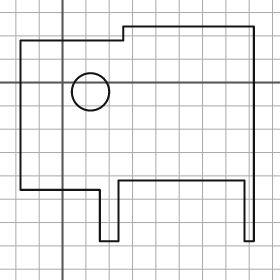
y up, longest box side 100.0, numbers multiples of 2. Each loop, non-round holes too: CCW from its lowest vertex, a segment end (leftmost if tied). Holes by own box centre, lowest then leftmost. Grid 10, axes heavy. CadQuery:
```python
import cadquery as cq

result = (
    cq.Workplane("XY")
    .moveTo(16.0, -68.0)
    .lineTo(24.0, -68.0)
    .lineTo(24.0, -42.0)
    .lineTo(78.0, -42.0)
    .lineTo(78.0, -68.0)
    .lineTo(82.0, -68.0)
    .lineTo(82.0, 24.0)
    .lineTo(26.0, 24.0)
    .lineTo(26.0, 18.0)
    .lineTo(-18.0, 18.0)
    .lineTo(-18.0, -46.0)
    .lineTo(16.0, -46.0)
    .close()
    .moveTo(12.0, -4.0)
    .circle(8.0)
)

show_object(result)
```